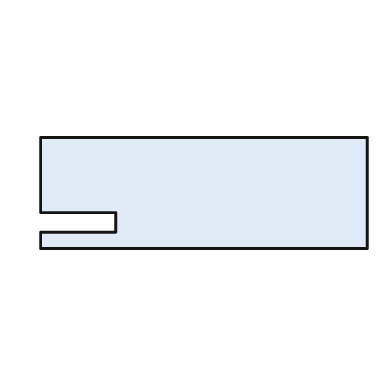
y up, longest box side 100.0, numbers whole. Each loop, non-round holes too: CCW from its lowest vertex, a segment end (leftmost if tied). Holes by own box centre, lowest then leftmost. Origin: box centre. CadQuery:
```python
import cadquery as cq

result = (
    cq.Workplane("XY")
    .moveTo(-50.0, -17.0)
    .lineTo(50.0, -17.0)
    .lineTo(50.0, 17.0)
    .lineTo(-50.0, 17.0)
    .lineTo(-50.0, -6.0)
    .lineTo(-27.0, -6.0)
    .lineTo(-27.0, -12.0)
    .lineTo(-50.0, -12.0)
    .close()
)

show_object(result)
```